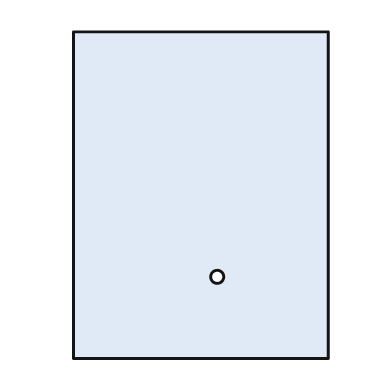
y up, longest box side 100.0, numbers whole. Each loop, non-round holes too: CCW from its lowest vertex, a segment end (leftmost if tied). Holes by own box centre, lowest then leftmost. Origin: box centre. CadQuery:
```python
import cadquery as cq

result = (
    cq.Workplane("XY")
    .moveTo(-39.0, -50.0)
    .lineTo(39.0, -50.0)
    .lineTo(39.0, 50.0)
    .lineTo(-39.0, 50.0)
    .close()
    .moveTo(5.0, -25.0)
    .circle(2.0)
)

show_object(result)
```